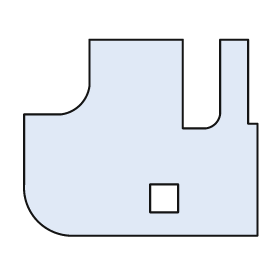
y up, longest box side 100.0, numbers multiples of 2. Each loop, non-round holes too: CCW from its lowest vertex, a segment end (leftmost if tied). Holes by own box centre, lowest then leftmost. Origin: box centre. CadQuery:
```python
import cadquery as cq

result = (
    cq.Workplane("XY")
    .moveTo(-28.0, -42.0)
    .lineTo(50.0, -42.0)
    .lineTo(50.0, 6.0)
    .lineTo(46.0, 6.0)
    .lineTo(46.0, 42.0)
    .lineTo(34.0, 42.0)
    .lineTo(34.0, 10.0)
    .threePointArc((32.0, 6.0), (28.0, 4.0))
    .lineTo(18.0, 4.0)
    .lineTo(18.0, 42.0)
    .lineTo(-22.0, 42.0)
    .lineTo(-22.0, 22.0)
    .threePointArc((-26.0, 14.0), (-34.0, 10.0))
    .lineTo(-50.0, 10.0)
    .lineTo(-50.0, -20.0)
    .threePointArc((-44.0, -36.0), (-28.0, -42.0))
    .close()
    .moveTo(4.0, -32.0)
    .lineTo(16.0, -32.0)
    .lineTo(16.0, -20.0)
    .lineTo(4.0, -20.0)
    .close()
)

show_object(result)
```